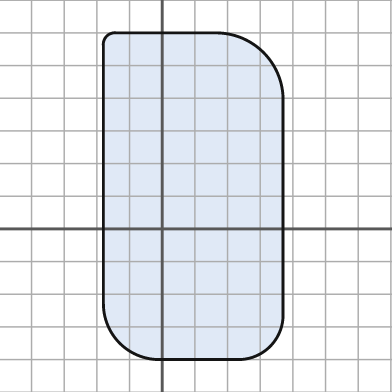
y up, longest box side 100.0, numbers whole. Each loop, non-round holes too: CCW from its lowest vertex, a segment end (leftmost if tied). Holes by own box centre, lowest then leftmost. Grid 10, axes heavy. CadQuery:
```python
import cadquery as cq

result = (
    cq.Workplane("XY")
    .moveTo(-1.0, -40.0)
    .lineTo(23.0, -40.0)
    .threePointArc((33.0, -36.0), (37.0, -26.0))
    .lineTo(37.0, 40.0)
    .threePointArc((31.0, 54.0), (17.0, 60.0))
    .lineTo(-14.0, 60.0)
    .threePointArc((-17.0, 59.0), (-18.0, 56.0))
    .lineTo(-18.0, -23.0)
    .threePointArc((-13.0, -35.0), (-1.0, -40.0))
    .close()
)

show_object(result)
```